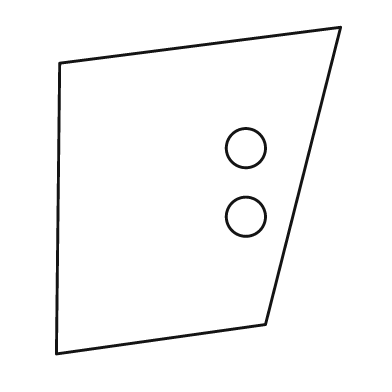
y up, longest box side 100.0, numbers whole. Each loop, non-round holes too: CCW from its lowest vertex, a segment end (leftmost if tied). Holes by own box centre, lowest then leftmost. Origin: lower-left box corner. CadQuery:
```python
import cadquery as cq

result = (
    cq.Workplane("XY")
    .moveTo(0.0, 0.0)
    .lineTo(64.0, 9.0)
    .lineTo(87.0, 100.0)
    .lineTo(1.0, 89.0)
    .close()
    .moveTo(58.0, 42.0)
    .circle(6.0)
    .moveTo(58.0, 63.0)
    .circle(6.0)
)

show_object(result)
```